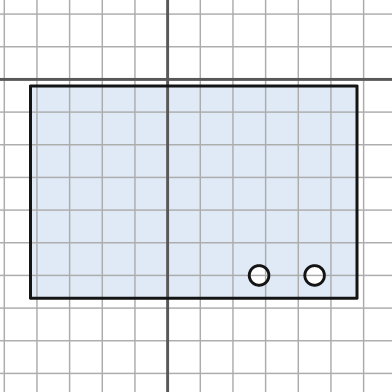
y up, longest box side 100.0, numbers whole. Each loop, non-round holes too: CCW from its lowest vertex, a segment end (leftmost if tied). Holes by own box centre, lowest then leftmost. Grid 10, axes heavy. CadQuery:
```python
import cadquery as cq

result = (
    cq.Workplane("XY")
    .moveTo(-42.0, -67.0)
    .lineTo(58.0, -67.0)
    .lineTo(58.0, -2.0)
    .lineTo(-42.0, -2.0)
    .close()
    .moveTo(28.0, -60.0)
    .circle(3.0)
    .moveTo(45.0, -60.0)
    .circle(3.0)
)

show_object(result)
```